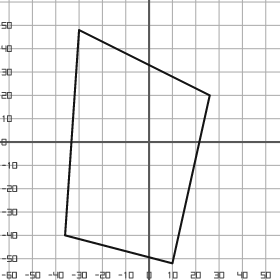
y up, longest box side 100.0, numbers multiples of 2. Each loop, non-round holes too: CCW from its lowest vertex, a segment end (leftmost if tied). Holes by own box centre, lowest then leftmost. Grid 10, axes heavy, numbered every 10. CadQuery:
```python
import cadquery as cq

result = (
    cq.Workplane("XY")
    .moveTo(10.0, -52.0)
    .lineTo(26.0, 20.0)
    .lineTo(-30.0, 48.0)
    .lineTo(-36.0, -40.0)
    .close()
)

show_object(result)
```